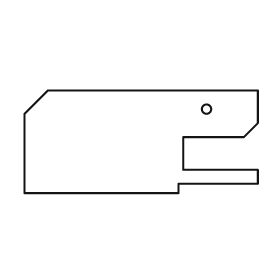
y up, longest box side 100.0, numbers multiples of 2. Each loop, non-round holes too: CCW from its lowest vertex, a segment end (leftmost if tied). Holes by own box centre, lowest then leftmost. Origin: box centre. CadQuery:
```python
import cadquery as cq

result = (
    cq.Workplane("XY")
    .moveTo(-50.0, -22.0)
    .lineTo(16.0, -22.0)
    .lineTo(16.0, -18.0)
    .lineTo(50.0, -18.0)
    .lineTo(50.0, -12.0)
    .lineTo(18.0, -12.0)
    .lineTo(18.0, 2.0)
    .lineTo(44.0, 2.0)
    .lineTo(50.0, 8.0)
    .lineTo(50.0, 22.0)
    .lineTo(-40.0, 22.0)
    .lineTo(-50.0, 12.0)
    .close()
    .moveTo(28.0, 14.0)
    .circle(2.0)
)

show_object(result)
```